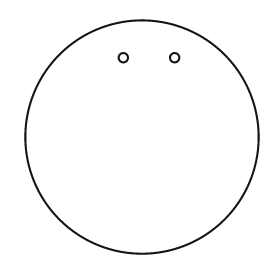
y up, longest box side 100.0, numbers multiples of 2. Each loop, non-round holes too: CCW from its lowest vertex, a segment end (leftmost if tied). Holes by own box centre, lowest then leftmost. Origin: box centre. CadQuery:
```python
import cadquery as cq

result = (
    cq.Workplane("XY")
    .moveTo(0.0, 0.0)
    .circle(50.0)
    .moveTo(-8.0, 34.0)
    .circle(2.0)
    .moveTo(14.0, 34.0)
    .circle(2.0)
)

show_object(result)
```